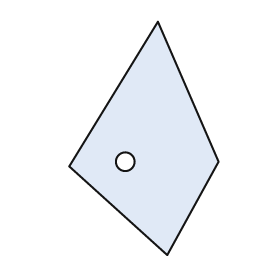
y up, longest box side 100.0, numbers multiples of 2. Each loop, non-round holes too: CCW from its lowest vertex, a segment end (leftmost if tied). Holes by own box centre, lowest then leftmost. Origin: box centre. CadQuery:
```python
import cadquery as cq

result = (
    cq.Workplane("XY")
    .moveTo(10.0, -50.0)
    .lineTo(32.0, -10.0)
    .lineTo(6.0, 50.0)
    .lineTo(-32.0, -12.0)
    .close()
    .moveTo(-8.0, -10.0)
    .circle(4.0)
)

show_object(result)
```